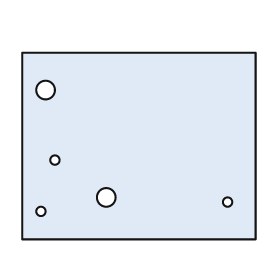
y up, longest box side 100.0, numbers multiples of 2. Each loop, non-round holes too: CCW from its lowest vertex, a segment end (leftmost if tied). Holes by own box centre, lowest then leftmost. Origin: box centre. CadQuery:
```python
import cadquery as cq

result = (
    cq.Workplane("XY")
    .moveTo(-50.0, -40.0)
    .lineTo(50.0, -40.0)
    .lineTo(50.0, 40.0)
    .lineTo(-50.0, 40.0)
    .close()
    .moveTo(-42.0, -28.0)
    .circle(2.0)
    .moveTo(38.0, -24.0)
    .circle(2.0)
    .moveTo(-14.0, -22.0)
    .circle(4.0)
    .moveTo(-36.0, -6.0)
    .circle(2.0)
    .moveTo(-40.0, 24.0)
    .circle(4.0)
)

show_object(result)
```